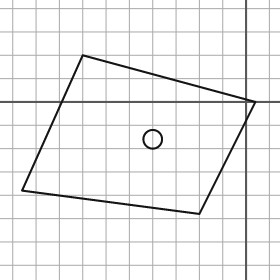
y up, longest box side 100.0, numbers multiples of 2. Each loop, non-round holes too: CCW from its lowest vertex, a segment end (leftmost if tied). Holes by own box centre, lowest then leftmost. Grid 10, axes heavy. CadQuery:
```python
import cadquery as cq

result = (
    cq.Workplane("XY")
    .moveTo(-20.0, -48.0)
    .lineTo(4.0, 0.0)
    .lineTo(-70.0, 20.0)
    .lineTo(-96.0, -38.0)
    .close()
    .moveTo(-40.0, -16.0)
    .circle(4.0)
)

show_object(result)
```